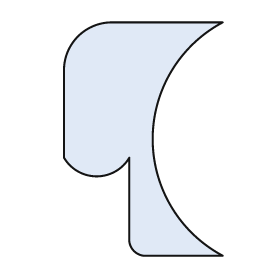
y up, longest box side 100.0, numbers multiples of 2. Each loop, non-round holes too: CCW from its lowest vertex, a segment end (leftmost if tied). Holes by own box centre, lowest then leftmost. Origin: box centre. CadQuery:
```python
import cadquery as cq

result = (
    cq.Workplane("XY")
    .moveTo(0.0, -50.0)
    .lineTo(34.0, -50.0)
    .threePointArc((4.0, 0.0), (34.0, 50.0))
    .lineTo(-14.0, 50.0)
    .threePointArc((-28.0, 44.0), (-34.0, 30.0))
    .lineTo(-34.0, -8.0)
    .threePointArc((-20.0, -16.0), (-6.0, -8.0))
    .lineTo(-6.0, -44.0)
    .threePointArc((-4.0, -48.0), (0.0, -50.0))
    .close()
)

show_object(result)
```